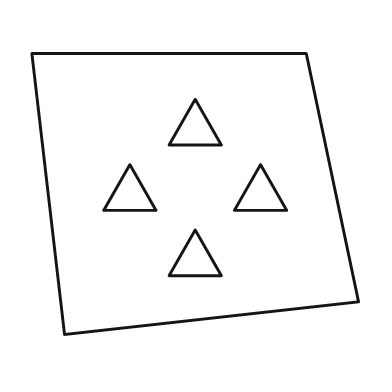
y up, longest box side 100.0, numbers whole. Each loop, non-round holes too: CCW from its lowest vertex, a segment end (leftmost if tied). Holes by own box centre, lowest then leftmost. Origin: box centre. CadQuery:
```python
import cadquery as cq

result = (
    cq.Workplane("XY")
    .moveTo(-40.0, -43.0)
    .lineTo(50.0, -33.0)
    .lineTo(34.0, 43.0)
    .lineTo(-50.0, 43.0)
    .close()
    .moveTo(-8.0, -25.0)
    .lineTo(8.0, -25.0)
    .lineTo(0.0, -11.0)
    .close()
    .moveTo(-28.0, -5.0)
    .lineTo(-12.0, -5.0)
    .lineTo(-20.0, 9.0)
    .close()
    .moveTo(12.0, -5.0)
    .lineTo(28.0, -5.0)
    .lineTo(20.0, 9.0)
    .close()
    .moveTo(-8.0, 15.0)
    .lineTo(8.0, 15.0)
    .lineTo(0.0, 29.0)
    .close()
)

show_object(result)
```